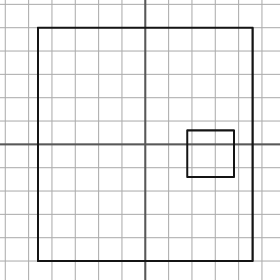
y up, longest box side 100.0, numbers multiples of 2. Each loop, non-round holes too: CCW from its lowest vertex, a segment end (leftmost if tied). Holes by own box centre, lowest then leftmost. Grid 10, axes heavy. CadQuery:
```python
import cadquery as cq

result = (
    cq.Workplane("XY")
    .moveTo(-46.0, -50.0)
    .lineTo(46.0, -50.0)
    .lineTo(46.0, 50.0)
    .lineTo(-46.0, 50.0)
    .close()
    .moveTo(18.0, -14.0)
    .lineTo(38.0, -14.0)
    .lineTo(38.0, 6.0)
    .lineTo(18.0, 6.0)
    .close()
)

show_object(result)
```